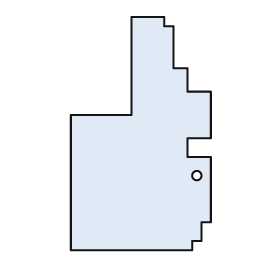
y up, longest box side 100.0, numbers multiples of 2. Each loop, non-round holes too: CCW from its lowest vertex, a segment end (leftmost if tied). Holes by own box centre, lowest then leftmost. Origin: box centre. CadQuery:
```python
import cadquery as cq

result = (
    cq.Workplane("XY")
    .moveTo(-30.0, -50.0)
    .lineTo(22.0, -50.0)
    .lineTo(22.0, -46.0)
    .lineTo(26.0, -46.0)
    .lineTo(26.0, -38.0)
    .lineTo(30.0, -38.0)
    .lineTo(30.0, -10.0)
    .lineTo(20.0, -10.0)
    .lineTo(20.0, -2.0)
    .lineTo(30.0, -2.0)
    .lineTo(30.0, 18.0)
    .lineTo(20.0, 18.0)
    .lineTo(20.0, 28.0)
    .lineTo(14.0, 28.0)
    .lineTo(14.0, 46.0)
    .lineTo(10.0, 46.0)
    .lineTo(10.0, 50.0)
    .lineTo(-4.0, 50.0)
    .lineTo(-4.0, 8.0)
    .lineTo(-30.0, 8.0)
    .close()
    .moveTo(24.0, -18.0)
    .circle(2.0)
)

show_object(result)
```